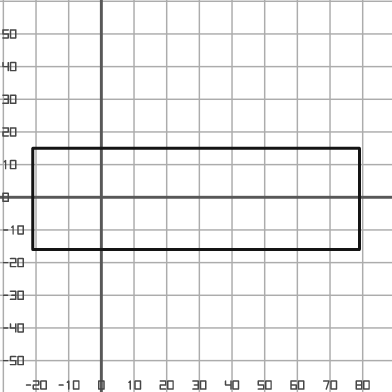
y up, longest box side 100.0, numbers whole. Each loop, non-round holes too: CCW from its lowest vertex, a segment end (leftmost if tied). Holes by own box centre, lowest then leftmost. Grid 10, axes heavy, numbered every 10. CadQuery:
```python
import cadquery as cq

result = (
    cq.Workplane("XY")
    .moveTo(-21.0, -16.0)
    .lineTo(79.0, -16.0)
    .lineTo(79.0, 15.0)
    .lineTo(-21.0, 15.0)
    .close()
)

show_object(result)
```